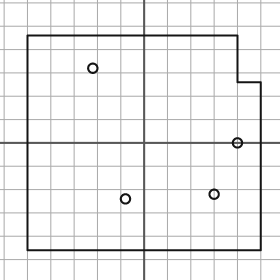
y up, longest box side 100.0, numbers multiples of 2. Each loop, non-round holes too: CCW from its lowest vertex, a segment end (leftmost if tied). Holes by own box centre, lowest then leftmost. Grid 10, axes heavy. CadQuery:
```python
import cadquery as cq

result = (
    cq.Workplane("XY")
    .moveTo(-50.0, -46.0)
    .lineTo(50.0, -46.0)
    .lineTo(50.0, 26.0)
    .lineTo(40.0, 26.0)
    .lineTo(40.0, 46.0)
    .lineTo(-50.0, 46.0)
    .close()
    .moveTo(-8.0, -24.0)
    .circle(2.0)
    .moveTo(30.0, -22.0)
    .circle(2.0)
    .moveTo(40.0, 0.0)
    .circle(2.0)
    .moveTo(-22.0, 32.0)
    .circle(2.0)
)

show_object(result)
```